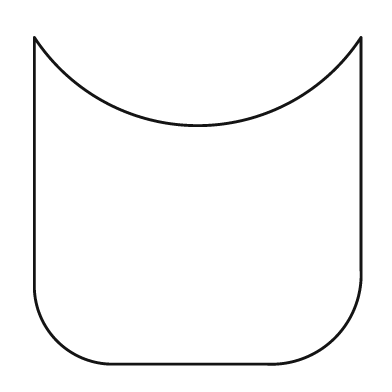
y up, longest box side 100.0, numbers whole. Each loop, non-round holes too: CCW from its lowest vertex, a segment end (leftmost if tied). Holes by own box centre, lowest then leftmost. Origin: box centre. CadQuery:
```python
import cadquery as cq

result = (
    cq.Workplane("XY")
    .moveTo(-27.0, -50.0)
    .lineTo(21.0, -50.0)
    .threePointArc((42.0, -42.0), (50.0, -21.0))
    .lineTo(50.0, 50.0)
    .threePointArc((0.0, 23.0), (-50.0, 50.0))
    .lineTo(-50.0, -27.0)
    .threePointArc((-43.0, -43.0), (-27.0, -50.0))
    .close()
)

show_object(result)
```